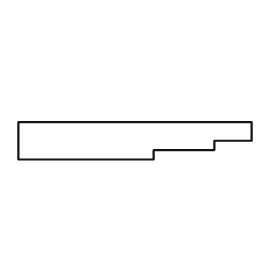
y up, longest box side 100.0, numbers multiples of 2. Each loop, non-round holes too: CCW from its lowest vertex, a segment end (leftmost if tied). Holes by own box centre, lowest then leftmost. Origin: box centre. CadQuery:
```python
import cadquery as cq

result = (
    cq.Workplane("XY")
    .moveTo(-50.0, -8.0)
    .lineTo(8.0, -8.0)
    .lineTo(8.0, -4.0)
    .lineTo(34.0, -4.0)
    .lineTo(34.0, 0.0)
    .lineTo(50.0, 0.0)
    .lineTo(50.0, 8.0)
    .lineTo(-50.0, 8.0)
    .close()
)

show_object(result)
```